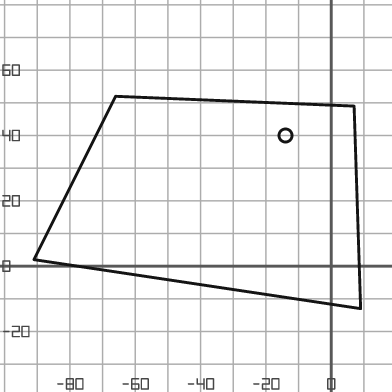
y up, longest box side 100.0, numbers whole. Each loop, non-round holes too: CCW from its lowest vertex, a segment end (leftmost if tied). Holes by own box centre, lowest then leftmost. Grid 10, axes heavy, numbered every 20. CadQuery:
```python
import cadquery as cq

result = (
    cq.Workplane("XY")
    .moveTo(9.0, -13.0)
    .lineTo(7.0, 49.0)
    .lineTo(-66.0, 52.0)
    .lineTo(-91.0, 2.0)
    .close()
    .moveTo(-14.0, 40.0)
    .circle(2.0)
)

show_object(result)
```